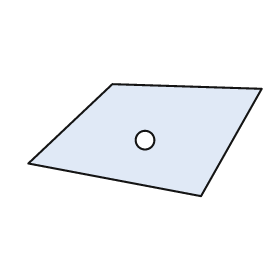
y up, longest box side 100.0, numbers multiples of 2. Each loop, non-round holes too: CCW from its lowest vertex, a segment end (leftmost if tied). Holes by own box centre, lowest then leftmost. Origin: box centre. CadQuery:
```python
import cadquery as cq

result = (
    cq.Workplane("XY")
    .moveTo(24.0, -24.0)
    .lineTo(50.0, 22.0)
    .lineTo(-14.0, 24.0)
    .lineTo(-50.0, -10.0)
    .close()
    .moveTo(0.0, 0.0)
    .circle(4.0)
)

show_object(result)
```